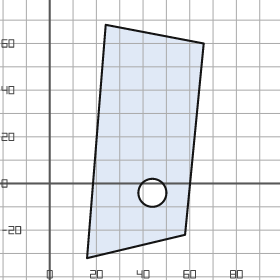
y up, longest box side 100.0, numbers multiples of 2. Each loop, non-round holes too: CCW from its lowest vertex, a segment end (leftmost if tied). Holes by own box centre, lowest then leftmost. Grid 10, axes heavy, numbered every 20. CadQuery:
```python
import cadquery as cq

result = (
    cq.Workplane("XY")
    .moveTo(16.0, -32.0)
    .lineTo(58.0, -22.0)
    .lineTo(66.0, 60.0)
    .lineTo(24.0, 68.0)
    .close()
    .moveTo(44.0, -4.0)
    .circle(6.0)
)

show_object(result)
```